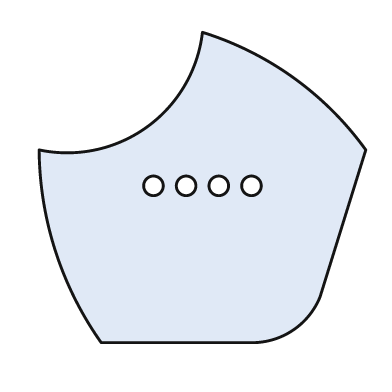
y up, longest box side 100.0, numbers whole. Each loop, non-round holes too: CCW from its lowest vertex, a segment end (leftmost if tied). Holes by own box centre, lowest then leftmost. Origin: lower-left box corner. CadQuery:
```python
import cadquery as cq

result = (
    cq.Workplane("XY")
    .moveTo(19.0, 0.0)
    .lineTo(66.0, 0.0)
    .threePointArc((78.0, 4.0), (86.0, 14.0))
    .lineTo(100.0, 59.0)
    .threePointArc((78.0, 81.0), (50.0, 95.0))
    .threePointArc((33.0, 66.0), (0.0, 59.0))
    .threePointArc((5.0, 28.0), (19.0, 0.0))
    .close()
    .moveTo(35.0, 48.0)
    .circle(3.0)
    .moveTo(45.0, 48.0)
    .circle(3.0)
    .moveTo(55.0, 48.0)
    .circle(3.0)
    .moveTo(65.0, 48.0)
    .circle(3.0)
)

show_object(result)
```